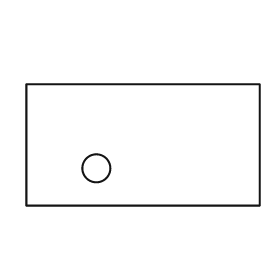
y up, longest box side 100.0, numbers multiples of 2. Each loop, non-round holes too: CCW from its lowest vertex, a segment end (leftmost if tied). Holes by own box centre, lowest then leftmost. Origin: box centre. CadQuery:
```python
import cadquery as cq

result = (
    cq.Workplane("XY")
    .moveTo(-50.0, -26.0)
    .lineTo(50.0, -26.0)
    .lineTo(50.0, 26.0)
    .lineTo(-50.0, 26.0)
    .close()
    .moveTo(-20.0, -10.0)
    .circle(6.0)
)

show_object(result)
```